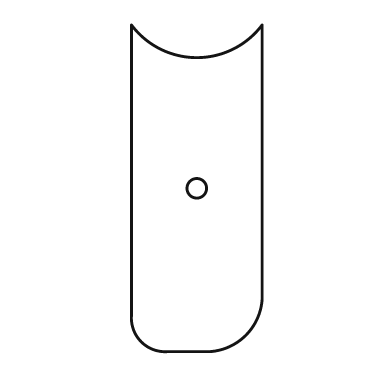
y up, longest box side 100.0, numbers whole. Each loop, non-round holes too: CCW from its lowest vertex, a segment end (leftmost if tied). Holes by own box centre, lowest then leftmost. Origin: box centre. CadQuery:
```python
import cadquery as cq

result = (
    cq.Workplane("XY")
    .moveTo(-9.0, -50.0)
    .lineTo(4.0, -50.0)
    .threePointArc((15.0, -45.0), (20.0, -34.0))
    .lineTo(20.0, 50.0)
    .threePointArc((0.0, 40.0), (-20.0, 50.0))
    .lineTo(-20.0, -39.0)
    .threePointArc((-17.0, -47.0), (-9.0, -50.0))
    .close()
    .moveTo(0.0, 0.0)
    .circle(3.0)
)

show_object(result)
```